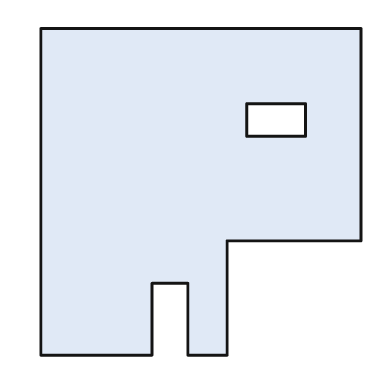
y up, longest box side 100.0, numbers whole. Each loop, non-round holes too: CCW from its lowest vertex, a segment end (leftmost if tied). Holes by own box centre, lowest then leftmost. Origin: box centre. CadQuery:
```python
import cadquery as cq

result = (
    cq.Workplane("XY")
    .moveTo(-49.0, -50.0)
    .lineTo(-15.0, -50.0)
    .lineTo(-15.0, -28.0)
    .lineTo(-4.0, -28.0)
    .lineTo(-4.0, -50.0)
    .lineTo(8.0, -50.0)
    .lineTo(8.0, -15.0)
    .lineTo(49.0, -15.0)
    .lineTo(49.0, 50.0)
    .lineTo(-49.0, 50.0)
    .close()
    .moveTo(14.0, 17.0)
    .lineTo(32.0, 17.0)
    .lineTo(32.0, 27.0)
    .lineTo(14.0, 27.0)
    .close()
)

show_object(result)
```